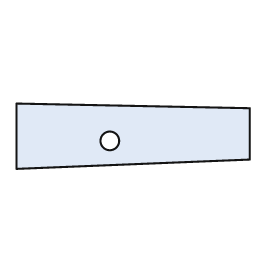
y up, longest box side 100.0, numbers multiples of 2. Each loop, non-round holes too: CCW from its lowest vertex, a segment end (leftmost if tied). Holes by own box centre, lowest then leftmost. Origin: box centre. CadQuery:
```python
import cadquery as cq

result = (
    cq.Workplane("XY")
    .moveTo(-50.0, -14.0)
    .lineTo(50.0, -10.0)
    .lineTo(50.0, 12.0)
    .lineTo(-50.0, 14.0)
    .close()
    .moveTo(-10.0, -2.0)
    .circle(4.0)
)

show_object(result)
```